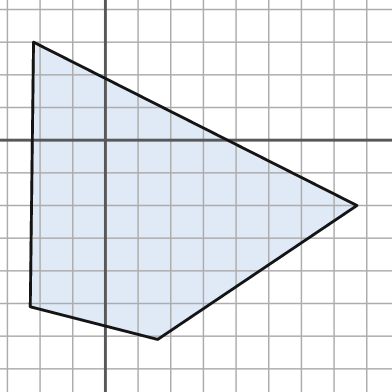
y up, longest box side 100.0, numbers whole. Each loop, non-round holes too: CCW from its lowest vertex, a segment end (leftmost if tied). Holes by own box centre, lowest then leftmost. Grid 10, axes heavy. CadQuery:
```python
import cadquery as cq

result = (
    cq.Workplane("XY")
    .moveTo(16.0, -61.0)
    .lineTo(77.0, -20.0)
    .lineTo(-22.0, 30.0)
    .lineTo(-23.0, -51.0)
    .close()
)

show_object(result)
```